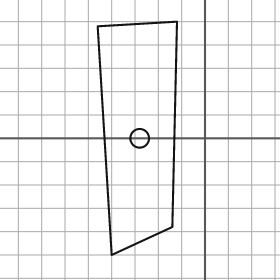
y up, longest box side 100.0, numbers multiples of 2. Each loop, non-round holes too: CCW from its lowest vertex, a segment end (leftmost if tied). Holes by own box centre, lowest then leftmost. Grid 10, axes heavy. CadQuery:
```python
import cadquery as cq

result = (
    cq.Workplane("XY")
    .moveTo(-40.0, -50.0)
    .lineTo(-14.0, -38.0)
    .lineTo(-12.0, 50.0)
    .lineTo(-46.0, 48.0)
    .close()
    .moveTo(-28.0, 0.0)
    .circle(4.0)
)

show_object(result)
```